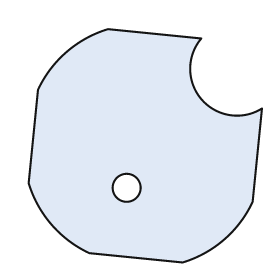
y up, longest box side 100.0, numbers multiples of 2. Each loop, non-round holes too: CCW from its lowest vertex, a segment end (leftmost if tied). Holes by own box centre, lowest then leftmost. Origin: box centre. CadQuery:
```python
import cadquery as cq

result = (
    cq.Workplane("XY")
    .moveTo(16.0, -50.0)
    .threePointArc((34.0, -40.0), (46.0, -24.0))
    .lineTo(50.0, 16.0)
    .threePointArc((24.0, 20.0), (24.0, 46.0))
    .lineTo(-16.0, 50.0)
    .threePointArc((-34.0, 40.0), (-46.0, 24.0))
    .lineTo(-50.0, -16.0)
    .threePointArc((-40.0, -34.0), (-24.0, -46.0))
    .close()
    .moveTo(-8.0, -18.0)
    .circle(6.0)
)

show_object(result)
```